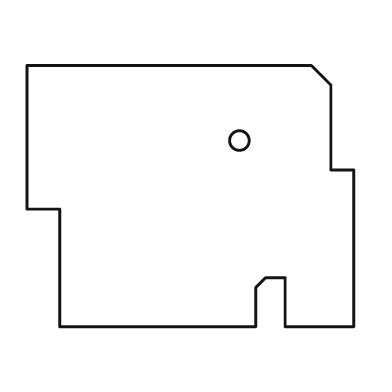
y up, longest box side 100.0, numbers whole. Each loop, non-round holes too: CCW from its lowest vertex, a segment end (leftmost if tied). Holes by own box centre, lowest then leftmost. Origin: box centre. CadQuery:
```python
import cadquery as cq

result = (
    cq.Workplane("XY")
    .moveTo(-40.0, -40.0)
    .lineTo(20.0, -40.0)
    .lineTo(20.0, -28.0)
    .lineTo(23.0, -25.0)
    .lineTo(29.0, -25.0)
    .lineTo(29.0, -40.0)
    .lineTo(50.0, -40.0)
    .lineTo(50.0, 8.0)
    .lineTo(43.0, 8.0)
    .lineTo(43.0, 34.0)
    .lineTo(37.0, 40.0)
    .lineTo(-50.0, 40.0)
    .lineTo(-50.0, -4.0)
    .lineTo(-40.0, -4.0)
    .close()
    .moveTo(15.0, 17.0)
    .circle(3.0)
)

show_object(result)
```